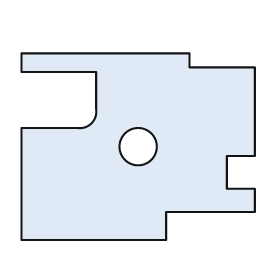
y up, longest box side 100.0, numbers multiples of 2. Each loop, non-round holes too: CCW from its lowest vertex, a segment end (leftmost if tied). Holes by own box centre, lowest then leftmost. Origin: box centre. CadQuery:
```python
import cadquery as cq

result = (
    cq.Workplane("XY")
    .moveTo(-50.0, -40.0)
    .lineTo(12.0, -40.0)
    .lineTo(12.0, -28.0)
    .lineTo(50.0, -28.0)
    .lineTo(50.0, -18.0)
    .lineTo(38.0, -18.0)
    .lineTo(38.0, -4.0)
    .lineTo(50.0, -4.0)
    .lineTo(50.0, 34.0)
    .lineTo(22.0, 34.0)
    .lineTo(22.0, 40.0)
    .lineTo(-50.0, 40.0)
    .lineTo(-50.0, 32.0)
    .lineTo(-18.0, 32.0)
    .lineTo(-18.0, 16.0)
    .threePointArc((-20.0, 10.0), (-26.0, 8.0))
    .lineTo(-50.0, 8.0)
    .close()
    .moveTo(0.0, 0.0)
    .circle(8.0)
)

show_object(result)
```